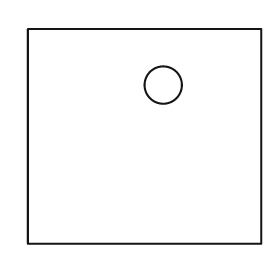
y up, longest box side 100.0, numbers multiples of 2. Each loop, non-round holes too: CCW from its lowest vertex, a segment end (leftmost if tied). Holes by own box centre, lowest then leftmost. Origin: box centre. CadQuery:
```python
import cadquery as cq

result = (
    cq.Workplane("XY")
    .moveTo(-50.0, -46.0)
    .lineTo(50.0, -46.0)
    .lineTo(50.0, 46.0)
    .lineTo(-50.0, 46.0)
    .close()
    .moveTo(8.0, 22.0)
    .circle(8.0)
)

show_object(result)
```